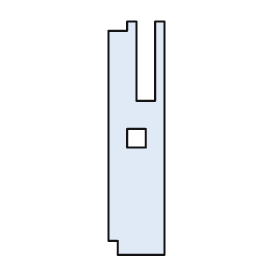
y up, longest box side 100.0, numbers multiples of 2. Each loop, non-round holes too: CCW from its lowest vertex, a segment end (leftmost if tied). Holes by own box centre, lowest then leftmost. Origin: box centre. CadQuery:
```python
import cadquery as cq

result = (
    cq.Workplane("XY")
    .moveTo(-8.0, -50.0)
    .lineTo(12.0, -50.0)
    .lineTo(12.0, 50.0)
    .lineTo(8.0, 50.0)
    .lineTo(8.0, 16.0)
    .lineTo(0.0, 16.0)
    .lineTo(0.0, 50.0)
    .lineTo(-4.0, 50.0)
    .lineTo(-4.0, 46.0)
    .lineTo(-12.0, 46.0)
    .lineTo(-12.0, -44.0)
    .lineTo(-8.0, -44.0)
    .close()
    .moveTo(-4.0, -4.0)
    .lineTo(4.0, -4.0)
    .lineTo(4.0, 4.0)
    .lineTo(-4.0, 4.0)
    .close()
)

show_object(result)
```